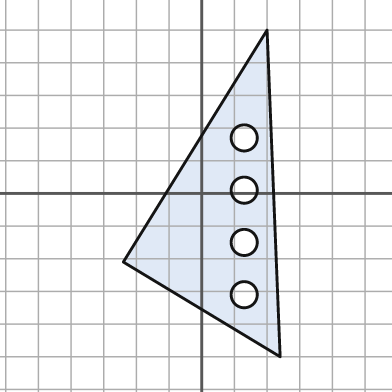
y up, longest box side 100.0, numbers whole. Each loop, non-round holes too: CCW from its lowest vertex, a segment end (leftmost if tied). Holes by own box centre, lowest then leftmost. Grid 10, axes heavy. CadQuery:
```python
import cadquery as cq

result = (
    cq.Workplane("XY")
    .moveTo(24.0, -50.0)
    .lineTo(20.0, 50.0)
    .lineTo(-24.0, -21.0)
    .close()
    .moveTo(13.0, -31.0)
    .circle(4.0)
    .moveTo(13.0, -15.0)
    .circle(4.0)
    .moveTo(13.0, 1.0)
    .circle(4.0)
    .moveTo(13.0, 17.0)
    .circle(4.0)
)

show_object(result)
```